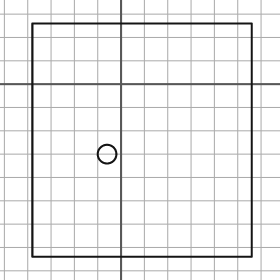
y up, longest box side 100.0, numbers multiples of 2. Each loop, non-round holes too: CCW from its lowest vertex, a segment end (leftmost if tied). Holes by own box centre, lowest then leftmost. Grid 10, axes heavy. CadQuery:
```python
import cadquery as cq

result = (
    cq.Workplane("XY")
    .moveTo(-38.0, -74.0)
    .lineTo(56.0, -74.0)
    .lineTo(56.0, 26.0)
    .lineTo(-38.0, 26.0)
    .close()
    .moveTo(-6.0, -30.0)
    .circle(4.0)
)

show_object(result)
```